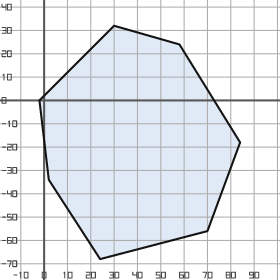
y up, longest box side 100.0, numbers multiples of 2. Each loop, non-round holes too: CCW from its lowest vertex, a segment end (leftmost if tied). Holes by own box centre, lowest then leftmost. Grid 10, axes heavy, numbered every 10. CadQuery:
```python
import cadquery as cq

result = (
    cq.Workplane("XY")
    .moveTo(24.0, -68.0)
    .lineTo(70.0, -56.0)
    .lineTo(84.0, -18.0)
    .lineTo(58.0, 24.0)
    .lineTo(30.0, 32.0)
    .lineTo(-2.0, 0.0)
    .lineTo(2.0, -34.0)
    .close()
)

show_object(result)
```